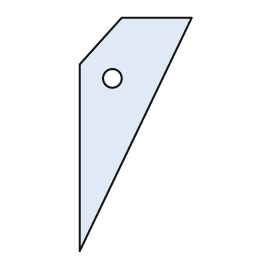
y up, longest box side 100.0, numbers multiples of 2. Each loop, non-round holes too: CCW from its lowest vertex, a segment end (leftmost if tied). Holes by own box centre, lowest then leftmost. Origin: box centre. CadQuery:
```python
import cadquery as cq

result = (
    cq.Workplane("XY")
    .moveTo(-24.0, -50.0)
    .lineTo(24.0, 50.0)
    .lineTo(-6.0, 50.0)
    .lineTo(-24.0, 30.0)
    .close()
    .moveTo(-10.0, 24.0)
    .circle(4.0)
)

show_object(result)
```